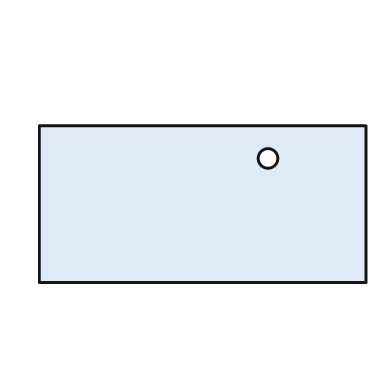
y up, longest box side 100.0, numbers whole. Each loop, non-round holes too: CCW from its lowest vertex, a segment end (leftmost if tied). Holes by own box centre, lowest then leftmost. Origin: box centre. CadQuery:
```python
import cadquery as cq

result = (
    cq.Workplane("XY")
    .moveTo(-50.0, -24.0)
    .lineTo(50.0, -24.0)
    .lineTo(50.0, 24.0)
    .lineTo(-50.0, 24.0)
    .close()
    .moveTo(20.0, 14.0)
    .circle(3.0)
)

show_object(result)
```